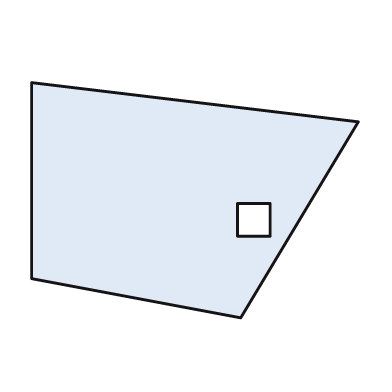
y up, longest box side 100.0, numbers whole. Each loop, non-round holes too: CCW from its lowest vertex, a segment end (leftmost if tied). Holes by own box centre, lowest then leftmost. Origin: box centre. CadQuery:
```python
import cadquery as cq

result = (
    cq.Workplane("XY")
    .moveTo(14.0, -36.0)
    .lineTo(50.0, 24.0)
    .lineTo(-50.0, 36.0)
    .lineTo(-50.0, -24.0)
    .close()
    .moveTo(13.0, -11.0)
    .lineTo(23.0, -11.0)
    .lineTo(23.0, -1.0)
    .lineTo(13.0, -1.0)
    .close()
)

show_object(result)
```